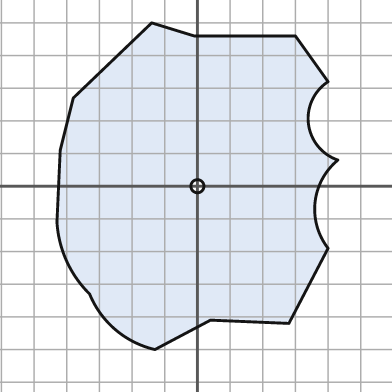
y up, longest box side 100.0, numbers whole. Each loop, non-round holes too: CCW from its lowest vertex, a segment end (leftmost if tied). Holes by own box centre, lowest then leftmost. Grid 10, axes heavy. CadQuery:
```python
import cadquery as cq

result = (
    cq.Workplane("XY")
    .moveTo(-13.0, -50.0)
    .lineTo(4.0, -41.0)
    .lineTo(28.0, -42.0)
    .lineTo(40.0, -19.0)
    .threePointArc((36.0, -5.0), (43.0, 8.0))
    .threePointArc((34.0, 19.0), (40.0, 32.0))
    .lineTo(30.0, 46.0)
    .lineTo(-1.0, 46.0)
    .lineTo(-14.0, 50.0)
    .lineTo(-38.0, 27.0)
    .lineTo(-42.0, 11.0)
    .lineTo(-43.0, -11.0)
    .threePointArc((-40.0, -23.0), (-33.0, -33.0))
    .threePointArc((-25.0, -44.0), (-13.0, -50.0))
    .close()
    .moveTo(0.0, 0.0)
    .circle(2.0)
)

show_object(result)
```